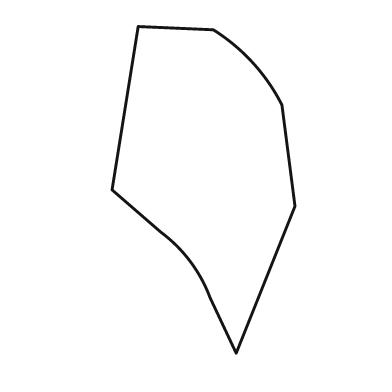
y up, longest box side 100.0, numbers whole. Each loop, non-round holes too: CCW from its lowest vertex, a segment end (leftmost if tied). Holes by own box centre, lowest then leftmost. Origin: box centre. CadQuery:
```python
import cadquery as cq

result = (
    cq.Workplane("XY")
    .moveTo(10.0, -50.0)
    .lineTo(28.0, -5.0)
    .lineTo(24.0, 26.0)
    .threePointArc((15.0, 39.0), (3.0, 49.0))
    .lineTo(-20.0, 50.0)
    .lineTo(-28.0, 0.0)
    .lineTo(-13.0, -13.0)
    .threePointArc((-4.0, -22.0), (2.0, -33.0))
    .close()
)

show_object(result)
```